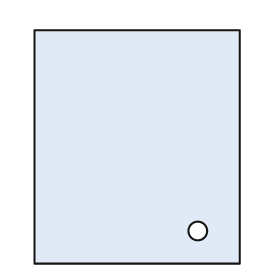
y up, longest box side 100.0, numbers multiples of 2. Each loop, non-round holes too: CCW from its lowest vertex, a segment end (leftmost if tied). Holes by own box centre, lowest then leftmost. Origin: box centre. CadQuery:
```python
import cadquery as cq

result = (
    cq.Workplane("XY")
    .moveTo(-44.0, -50.0)
    .lineTo(44.0, -50.0)
    .lineTo(44.0, 50.0)
    .lineTo(-44.0, 50.0)
    .close()
    .moveTo(26.0, -36.0)
    .circle(4.0)
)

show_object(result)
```